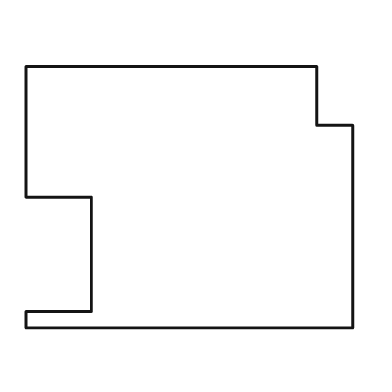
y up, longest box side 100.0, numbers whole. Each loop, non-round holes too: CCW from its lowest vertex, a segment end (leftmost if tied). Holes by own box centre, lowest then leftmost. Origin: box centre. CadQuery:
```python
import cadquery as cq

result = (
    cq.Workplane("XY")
    .moveTo(-50.0, -40.0)
    .lineTo(50.0, -40.0)
    .lineTo(50.0, 22.0)
    .lineTo(39.0, 22.0)
    .lineTo(39.0, 40.0)
    .lineTo(-50.0, 40.0)
    .lineTo(-50.0, 0.0)
    .lineTo(-30.0, 0.0)
    .lineTo(-30.0, -35.0)
    .lineTo(-50.0, -35.0)
    .close()
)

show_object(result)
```